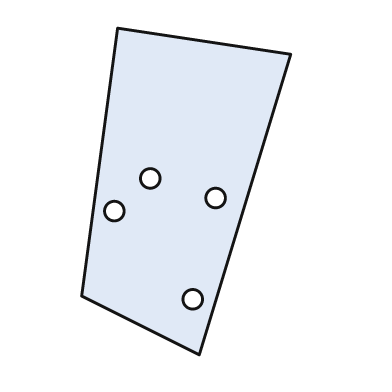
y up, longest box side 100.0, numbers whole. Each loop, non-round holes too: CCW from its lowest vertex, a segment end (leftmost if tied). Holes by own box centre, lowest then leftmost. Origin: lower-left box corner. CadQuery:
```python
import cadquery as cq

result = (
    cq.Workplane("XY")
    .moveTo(36.0, 0.0)
    .lineTo(64.0, 92.0)
    .lineTo(11.0, 100.0)
    .lineTo(0.0, 18.0)
    .close()
    .moveTo(34.0, 17.0)
    .circle(3.0)
    .moveTo(10.0, 44.0)
    .circle(3.0)
    .moveTo(41.0, 48.0)
    .circle(3.0)
    .moveTo(21.0, 54.0)
    .circle(3.0)
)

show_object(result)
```